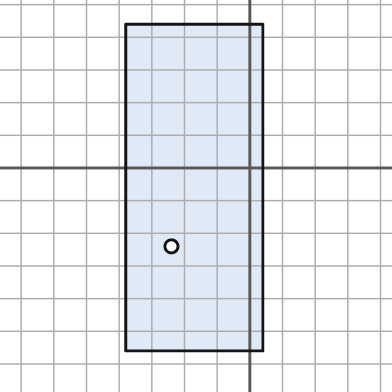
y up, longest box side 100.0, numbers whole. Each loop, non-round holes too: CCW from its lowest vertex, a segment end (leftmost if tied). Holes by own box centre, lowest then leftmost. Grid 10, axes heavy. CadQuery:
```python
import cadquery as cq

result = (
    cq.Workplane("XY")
    .moveTo(-38.0, -56.0)
    .lineTo(4.0, -56.0)
    .lineTo(4.0, 44.0)
    .lineTo(-38.0, 44.0)
    .close()
    .moveTo(-24.0, -24.0)
    .circle(2.0)
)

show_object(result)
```